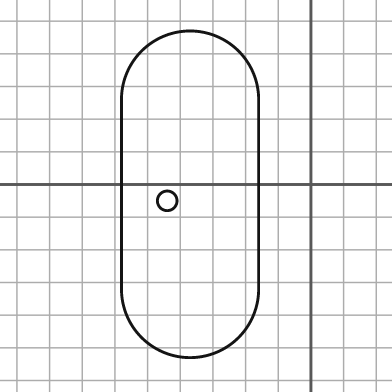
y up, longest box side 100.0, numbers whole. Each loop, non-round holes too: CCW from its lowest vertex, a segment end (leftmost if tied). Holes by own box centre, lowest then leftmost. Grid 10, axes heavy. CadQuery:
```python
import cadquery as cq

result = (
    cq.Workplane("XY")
    .moveTo(-58.0, -32.0)
    .threePointArc((-37.0, -53.0), (-16.0, -32.0))
    .lineTo(-16.0, 26.0)
    .threePointArc((-37.0, 47.0), (-58.0, 26.0))
    .close()
    .moveTo(-44.0, -5.0)
    .circle(3.0)
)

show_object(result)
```